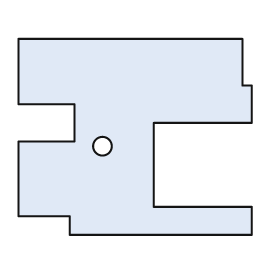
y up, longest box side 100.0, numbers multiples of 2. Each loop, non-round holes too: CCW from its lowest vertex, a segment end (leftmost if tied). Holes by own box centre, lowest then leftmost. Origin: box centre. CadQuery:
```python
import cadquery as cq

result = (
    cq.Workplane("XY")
    .moveTo(-28.0, -42.0)
    .lineTo(50.0, -42.0)
    .lineTo(50.0, -30.0)
    .lineTo(8.0, -30.0)
    .lineTo(8.0, 6.0)
    .lineTo(50.0, 6.0)
    .lineTo(50.0, 22.0)
    .lineTo(46.0, 22.0)
    .lineTo(46.0, 42.0)
    .lineTo(-50.0, 42.0)
    .lineTo(-50.0, 14.0)
    .lineTo(-26.0, 14.0)
    .lineTo(-26.0, -2.0)
    .lineTo(-50.0, -2.0)
    .lineTo(-50.0, -34.0)
    .lineTo(-28.0, -34.0)
    .close()
    .moveTo(-14.0, -4.0)
    .circle(4.0)
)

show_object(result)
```